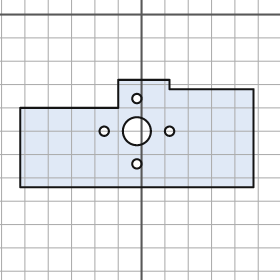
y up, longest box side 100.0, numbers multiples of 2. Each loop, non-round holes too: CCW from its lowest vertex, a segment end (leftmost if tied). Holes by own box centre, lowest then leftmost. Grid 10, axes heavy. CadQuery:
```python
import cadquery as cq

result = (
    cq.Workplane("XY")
    .moveTo(-52.0, -74.0)
    .lineTo(48.0, -74.0)
    .lineTo(48.0, -32.0)
    .lineTo(12.0, -32.0)
    .lineTo(12.0, -28.0)
    .lineTo(-10.0, -28.0)
    .lineTo(-10.0, -40.0)
    .lineTo(-52.0, -40.0)
    .close()
    .moveTo(-2.0, -64.0)
    .circle(2.0)
    .moveTo(-16.0, -50.0)
    .circle(2.0)
    .moveTo(-2.0, -50.0)
    .circle(6.0)
    .moveTo(12.0, -50.0)
    .circle(2.0)
    .moveTo(-2.0, -36.0)
    .circle(2.0)
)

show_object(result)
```